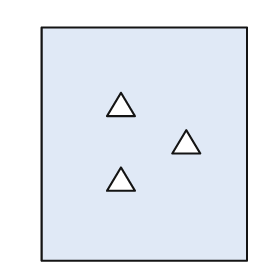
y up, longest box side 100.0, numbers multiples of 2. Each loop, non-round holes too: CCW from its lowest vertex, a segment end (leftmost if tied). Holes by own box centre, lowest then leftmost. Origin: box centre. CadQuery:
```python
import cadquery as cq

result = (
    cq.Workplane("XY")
    .moveTo(-44.0, -50.0)
    .lineTo(44.0, -50.0)
    .lineTo(44.0, 50.0)
    .lineTo(-44.0, 50.0)
    .close()
    .moveTo(-16.0, -20.0)
    .lineTo(-4.0, -20.0)
    .lineTo(-10.0, -10.0)
    .close()
    .moveTo(12.0, -4.0)
    .lineTo(24.0, -4.0)
    .lineTo(18.0, 6.0)
    .close()
    .moveTo(-16.0, 12.0)
    .lineTo(-4.0, 12.0)
    .lineTo(-10.0, 22.0)
    .close()
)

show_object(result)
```